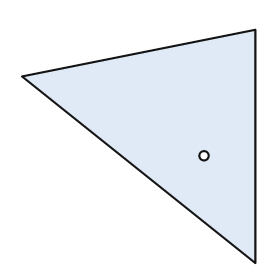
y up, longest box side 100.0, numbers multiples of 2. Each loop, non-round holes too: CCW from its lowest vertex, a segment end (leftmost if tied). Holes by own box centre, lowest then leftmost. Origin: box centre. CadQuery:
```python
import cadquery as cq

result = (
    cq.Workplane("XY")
    .moveTo(50.0, -50.0)
    .lineTo(50.0, 50.0)
    .lineTo(-50.0, 30.0)
    .close()
    .moveTo(28.0, -4.0)
    .circle(2.0)
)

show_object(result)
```